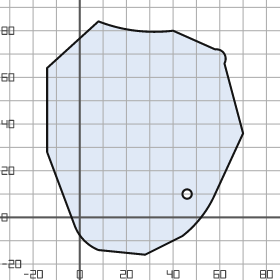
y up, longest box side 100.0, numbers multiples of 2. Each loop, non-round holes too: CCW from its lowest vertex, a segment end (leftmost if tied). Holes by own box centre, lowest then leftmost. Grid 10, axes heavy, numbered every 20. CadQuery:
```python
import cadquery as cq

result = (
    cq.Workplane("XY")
    .moveTo(28.0, -16.0)
    .lineTo(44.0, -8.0)
    .threePointArc((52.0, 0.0), (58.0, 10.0))
    .lineTo(70.0, 36.0)
    .lineTo(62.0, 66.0)
    .threePointArc((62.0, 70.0), (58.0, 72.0))
    .lineTo(40.0, 80.0)
    .threePointArc((24.0, 80.0), (8.0, 84.0))
    .lineTo(-14.0, 64.0)
    .lineTo(-14.0, 28.0)
    .lineTo(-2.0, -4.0)
    .threePointArc((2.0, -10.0), (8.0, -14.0))
    .close()
    .moveTo(46.0, 10.0)
    .circle(2.0)
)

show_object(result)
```